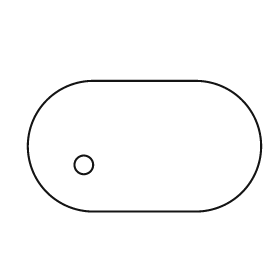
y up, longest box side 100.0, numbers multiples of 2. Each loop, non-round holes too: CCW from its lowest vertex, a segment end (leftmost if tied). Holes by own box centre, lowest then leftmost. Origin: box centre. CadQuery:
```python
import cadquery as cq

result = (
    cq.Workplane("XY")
    .moveTo(-22.0, -28.0)
    .lineTo(22.0, -28.0)
    .threePointArc((50.0, 0.0), (22.0, 28.0))
    .lineTo(-22.0, 28.0)
    .threePointArc((-50.0, 0.0), (-22.0, -28.0))
    .close()
    .moveTo(-26.0, -8.0)
    .circle(4.0)
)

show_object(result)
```